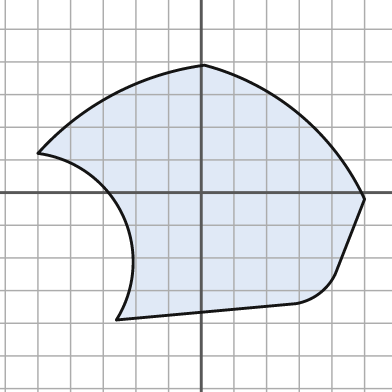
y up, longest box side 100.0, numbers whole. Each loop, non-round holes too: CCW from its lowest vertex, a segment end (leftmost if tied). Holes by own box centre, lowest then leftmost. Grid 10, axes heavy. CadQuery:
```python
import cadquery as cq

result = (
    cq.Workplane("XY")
    .moveTo(-26.0, -39.0)
    .lineTo(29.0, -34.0)
    .threePointArc((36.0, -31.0), (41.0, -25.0))
    .lineTo(50.0, -2.0)
    .threePointArc((30.0, 24.0), (1.0, 39.0))
    .threePointArc((-27.0, 30.0), (-50.0, 12.0))
    .threePointArc((-24.0, -7.0), (-26.0, -39.0))
    .close()
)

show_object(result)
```